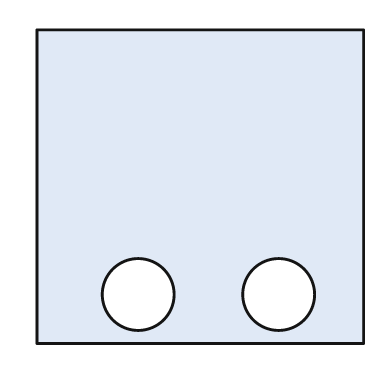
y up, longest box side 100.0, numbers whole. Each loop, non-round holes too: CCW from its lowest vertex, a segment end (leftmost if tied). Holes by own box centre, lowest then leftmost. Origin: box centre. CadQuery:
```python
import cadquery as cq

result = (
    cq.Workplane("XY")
    .moveTo(-50.0, -48.0)
    .lineTo(50.0, -48.0)
    .lineTo(50.0, 48.0)
    .lineTo(-50.0, 48.0)
    .close()
    .moveTo(-19.0, -33.0)
    .circle(11.0)
    .moveTo(24.0, -33.0)
    .circle(11.0)
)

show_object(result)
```